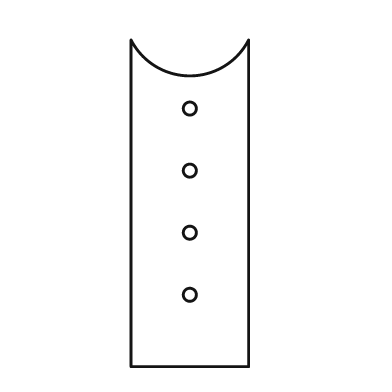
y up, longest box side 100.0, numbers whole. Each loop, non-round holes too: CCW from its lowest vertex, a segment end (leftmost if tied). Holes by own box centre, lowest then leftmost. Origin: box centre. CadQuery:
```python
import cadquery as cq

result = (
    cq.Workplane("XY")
    .moveTo(-18.0, -50.0)
    .lineTo(18.0, -50.0)
    .lineTo(18.0, 50.0)
    .threePointArc((0.0, 39.0), (-18.0, 50.0))
    .close()
    .moveTo(0.0, -28.0)
    .circle(2.0)
    .moveTo(0.0, -9.0)
    .circle(2.0)
    .moveTo(0.0, 10.0)
    .circle(2.0)
    .moveTo(0.0, 29.0)
    .circle(2.0)
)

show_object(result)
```